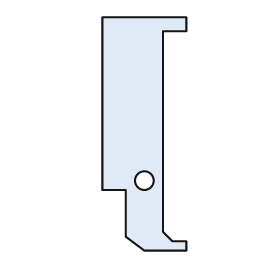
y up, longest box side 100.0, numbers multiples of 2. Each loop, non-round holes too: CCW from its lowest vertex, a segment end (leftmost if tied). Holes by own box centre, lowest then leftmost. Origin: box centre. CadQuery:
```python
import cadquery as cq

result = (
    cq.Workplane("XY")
    .moveTo(0.0, -50.0)
    .lineTo(18.0, -50.0)
    .lineTo(18.0, -46.0)
    .lineTo(12.0, -46.0)
    .lineTo(8.0, -42.0)
    .lineTo(8.0, 44.0)
    .lineTo(18.0, 44.0)
    .lineTo(18.0, 50.0)
    .lineTo(-18.0, 50.0)
    .lineTo(-18.0, -24.0)
    .lineTo(-8.0, -24.0)
    .lineTo(-8.0, -44.0)
    .close()
    .moveTo(0.0, -20.0)
    .circle(4.0)
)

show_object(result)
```